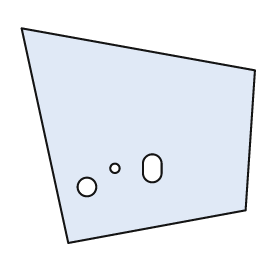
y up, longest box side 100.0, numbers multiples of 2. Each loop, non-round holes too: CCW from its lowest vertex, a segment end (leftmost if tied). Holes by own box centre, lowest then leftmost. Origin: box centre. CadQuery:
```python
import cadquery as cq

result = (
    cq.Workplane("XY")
    .moveTo(-30.0, -46.0)
    .lineTo(46.0, -32.0)
    .lineTo(50.0, 28.0)
    .lineTo(-50.0, 46.0)
    .close()
    .moveTo(-22.0, -22.0)
    .circle(4.0)
    .moveTo(-10.0, -14.0)
    .circle(2.0)
    .moveTo(2.0, -16.0)
    .threePointArc((6.0, -20.0), (10.0, -16.0))
    .lineTo(10.0, -12.0)
    .threePointArc((6.0, -8.0), (2.0, -12.0))
    .close()
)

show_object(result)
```